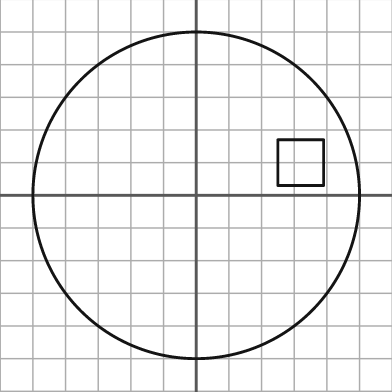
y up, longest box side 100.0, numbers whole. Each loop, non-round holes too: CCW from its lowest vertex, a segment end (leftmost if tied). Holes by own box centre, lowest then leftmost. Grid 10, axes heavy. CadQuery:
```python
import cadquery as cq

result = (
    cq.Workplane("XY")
    .moveTo(0.0, 0.0)
    .circle(50.0)
    .moveTo(25.0, 3.0)
    .lineTo(39.0, 3.0)
    .lineTo(39.0, 17.0)
    .lineTo(25.0, 17.0)
    .close()
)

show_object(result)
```